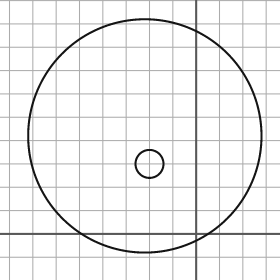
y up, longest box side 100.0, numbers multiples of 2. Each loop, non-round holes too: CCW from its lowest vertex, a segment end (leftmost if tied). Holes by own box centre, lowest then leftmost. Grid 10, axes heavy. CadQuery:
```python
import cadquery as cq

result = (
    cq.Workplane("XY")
    .moveTo(-22.0, 42.0)
    .circle(50.0)
    .moveTo(-20.0, 30.0)
    .circle(6.0)
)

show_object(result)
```